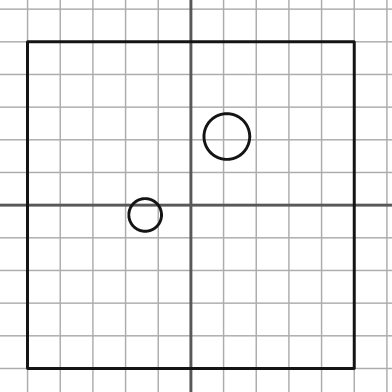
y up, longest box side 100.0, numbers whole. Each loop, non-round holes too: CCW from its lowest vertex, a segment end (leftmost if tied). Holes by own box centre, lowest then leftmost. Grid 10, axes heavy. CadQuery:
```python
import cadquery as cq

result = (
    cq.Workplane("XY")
    .moveTo(-50.0, -50.0)
    .lineTo(50.0, -50.0)
    .lineTo(50.0, 50.0)
    .lineTo(-50.0, 50.0)
    .close()
    .moveTo(-14.0, -3.0)
    .circle(5.0)
    .moveTo(11.0, 21.0)
    .circle(7.0)
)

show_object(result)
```